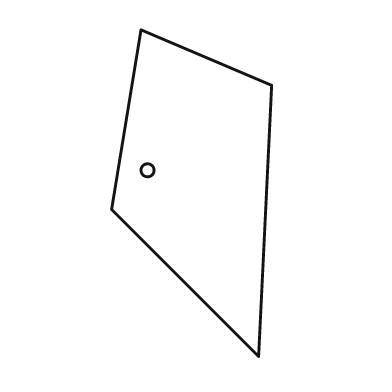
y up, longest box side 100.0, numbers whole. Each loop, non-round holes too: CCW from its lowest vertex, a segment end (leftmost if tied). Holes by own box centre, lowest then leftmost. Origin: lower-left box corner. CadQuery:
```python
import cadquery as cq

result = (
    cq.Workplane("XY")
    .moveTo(45.0, 0.0)
    .lineTo(49.0, 83.0)
    .lineTo(9.0, 100.0)
    .lineTo(0.0, 45.0)
    .close()
    .moveTo(11.0, 57.0)
    .circle(2.0)
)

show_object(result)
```